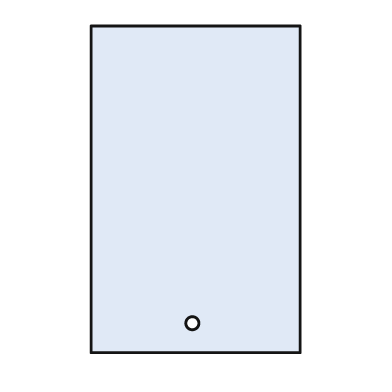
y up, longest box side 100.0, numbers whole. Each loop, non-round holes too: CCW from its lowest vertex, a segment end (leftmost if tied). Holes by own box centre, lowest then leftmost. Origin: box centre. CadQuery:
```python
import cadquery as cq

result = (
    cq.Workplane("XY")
    .moveTo(-32.0, -50.0)
    .lineTo(32.0, -50.0)
    .lineTo(32.0, 50.0)
    .lineTo(-32.0, 50.0)
    .close()
    .moveTo(-1.0, -41.0)
    .circle(2.0)
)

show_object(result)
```